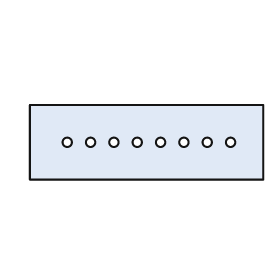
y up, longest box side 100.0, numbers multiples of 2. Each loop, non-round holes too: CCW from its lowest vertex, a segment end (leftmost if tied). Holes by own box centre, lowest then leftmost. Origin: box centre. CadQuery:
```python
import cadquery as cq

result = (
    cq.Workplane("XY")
    .moveTo(-50.0, -16.0)
    .lineTo(50.0, -16.0)
    .lineTo(50.0, 16.0)
    .lineTo(-50.0, 16.0)
    .close()
    .moveTo(-34.0, 0.0)
    .circle(2.0)
    .moveTo(-24.0, 0.0)
    .circle(2.0)
    .moveTo(-14.0, 0.0)
    .circle(2.0)
    .moveTo(-4.0, 0.0)
    .circle(2.0)
    .moveTo(6.0, 0.0)
    .circle(2.0)
    .moveTo(16.0, 0.0)
    .circle(2.0)
    .moveTo(26.0, 0.0)
    .circle(2.0)
    .moveTo(36.0, 0.0)
    .circle(2.0)
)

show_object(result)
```